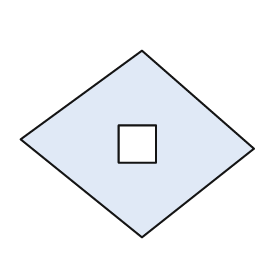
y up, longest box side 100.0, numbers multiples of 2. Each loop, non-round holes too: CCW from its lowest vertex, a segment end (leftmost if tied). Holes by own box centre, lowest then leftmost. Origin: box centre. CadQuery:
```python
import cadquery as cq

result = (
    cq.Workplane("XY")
    .moveTo(2.0, -40.0)
    .lineTo(50.0, -2.0)
    .lineTo(2.0, 40.0)
    .lineTo(-50.0, 2.0)
    .close()
    .moveTo(-8.0, -8.0)
    .lineTo(8.0, -8.0)
    .lineTo(8.0, 8.0)
    .lineTo(-8.0, 8.0)
    .close()
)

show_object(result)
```